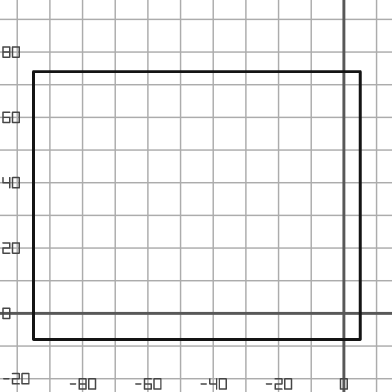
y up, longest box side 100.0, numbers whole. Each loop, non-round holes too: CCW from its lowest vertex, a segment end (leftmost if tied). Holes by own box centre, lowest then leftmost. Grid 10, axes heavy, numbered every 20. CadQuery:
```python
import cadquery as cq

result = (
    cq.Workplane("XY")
    .moveTo(-95.0, -8.0)
    .lineTo(5.0, -8.0)
    .lineTo(5.0, 74.0)
    .lineTo(-95.0, 74.0)
    .close()
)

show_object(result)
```